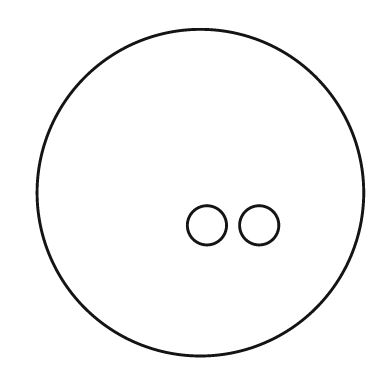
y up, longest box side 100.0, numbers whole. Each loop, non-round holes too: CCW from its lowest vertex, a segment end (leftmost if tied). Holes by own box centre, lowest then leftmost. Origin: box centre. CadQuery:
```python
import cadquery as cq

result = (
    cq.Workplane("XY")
    .moveTo(0.0, 0.0)
    .circle(50.0)
    .moveTo(2.0, -10.0)
    .circle(6.0)
    .moveTo(18.0, -10.0)
    .circle(6.0)
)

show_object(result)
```